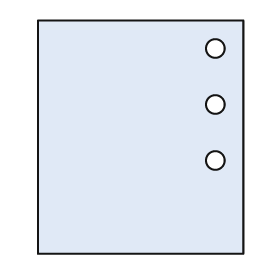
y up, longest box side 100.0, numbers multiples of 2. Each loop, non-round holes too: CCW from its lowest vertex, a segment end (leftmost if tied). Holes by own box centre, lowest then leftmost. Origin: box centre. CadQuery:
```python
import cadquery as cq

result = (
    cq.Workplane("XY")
    .moveTo(-44.0, -50.0)
    .lineTo(44.0, -50.0)
    .lineTo(44.0, 50.0)
    .lineTo(-44.0, 50.0)
    .close()
    .moveTo(32.0, -10.0)
    .circle(4.0)
    .moveTo(32.0, 14.0)
    .circle(4.0)
    .moveTo(32.0, 38.0)
    .circle(4.0)
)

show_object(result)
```